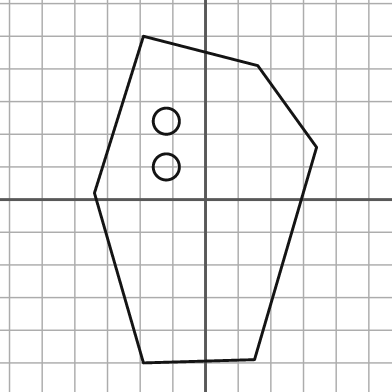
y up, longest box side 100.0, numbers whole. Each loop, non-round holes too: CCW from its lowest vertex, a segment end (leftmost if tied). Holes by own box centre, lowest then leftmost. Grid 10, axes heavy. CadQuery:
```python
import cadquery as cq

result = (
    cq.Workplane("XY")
    .moveTo(-19.0, -50.0)
    .lineTo(15.0, -49.0)
    .lineTo(34.0, 16.0)
    .lineTo(16.0, 41.0)
    .lineTo(-19.0, 50.0)
    .lineTo(-34.0, 2.0)
    .close()
    .moveTo(-12.0, 10.0)
    .circle(4.0)
    .moveTo(-12.0, 24.0)
    .circle(4.0)
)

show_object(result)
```